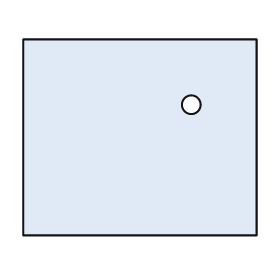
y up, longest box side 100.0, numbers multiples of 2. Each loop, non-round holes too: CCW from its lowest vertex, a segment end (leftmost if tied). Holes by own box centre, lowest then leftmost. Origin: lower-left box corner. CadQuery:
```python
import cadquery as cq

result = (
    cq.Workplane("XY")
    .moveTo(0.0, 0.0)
    .lineTo(100.0, 0.0)
    .lineTo(100.0, 84.0)
    .lineTo(0.0, 84.0)
    .close()
    .moveTo(72.0, 56.0)
    .circle(4.0)
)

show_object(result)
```